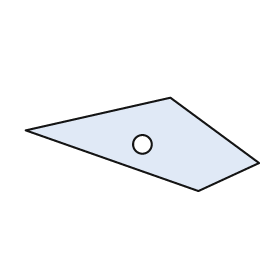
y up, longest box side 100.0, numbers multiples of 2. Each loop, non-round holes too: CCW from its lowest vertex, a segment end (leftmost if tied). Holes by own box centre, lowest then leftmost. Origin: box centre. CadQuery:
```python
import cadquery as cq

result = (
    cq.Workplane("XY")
    .moveTo(24.0, -20.0)
    .lineTo(50.0, -8.0)
    .lineTo(12.0, 20.0)
    .lineTo(-50.0, 6.0)
    .close()
    .moveTo(0.0, 0.0)
    .circle(4.0)
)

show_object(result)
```